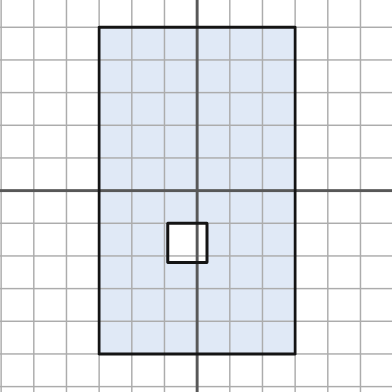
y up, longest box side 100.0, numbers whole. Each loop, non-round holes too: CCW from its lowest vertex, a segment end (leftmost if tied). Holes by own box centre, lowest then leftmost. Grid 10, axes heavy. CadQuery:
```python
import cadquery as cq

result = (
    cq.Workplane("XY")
    .moveTo(-30.0, -50.0)
    .lineTo(30.0, -50.0)
    .lineTo(30.0, 50.0)
    .lineTo(-30.0, 50.0)
    .close()
    .moveTo(-9.0, -22.0)
    .lineTo(3.0, -22.0)
    .lineTo(3.0, -10.0)
    .lineTo(-9.0, -10.0)
    .close()
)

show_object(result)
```